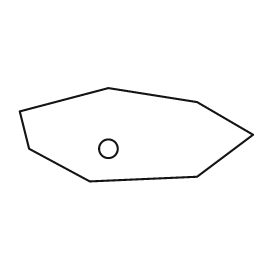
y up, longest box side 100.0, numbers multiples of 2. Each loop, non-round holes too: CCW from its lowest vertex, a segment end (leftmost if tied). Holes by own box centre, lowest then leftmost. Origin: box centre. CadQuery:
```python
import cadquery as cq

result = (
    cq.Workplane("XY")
    .moveTo(-20.0, -20.0)
    .lineTo(26.0, -18.0)
    .lineTo(50.0, 0.0)
    .lineTo(26.0, 14.0)
    .lineTo(-12.0, 20.0)
    .lineTo(-50.0, 10.0)
    .lineTo(-46.0, -6.0)
    .close()
    .moveTo(-12.0, -6.0)
    .circle(4.0)
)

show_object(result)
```